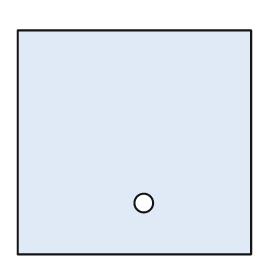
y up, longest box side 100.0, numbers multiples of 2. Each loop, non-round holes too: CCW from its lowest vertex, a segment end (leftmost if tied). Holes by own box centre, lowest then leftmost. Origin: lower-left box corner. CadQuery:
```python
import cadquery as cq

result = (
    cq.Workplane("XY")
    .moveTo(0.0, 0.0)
    .lineTo(100.0, 0.0)
    .lineTo(100.0, 96.0)
    .lineTo(0.0, 96.0)
    .close()
    .moveTo(54.0, 22.0)
    .circle(4.0)
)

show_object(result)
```